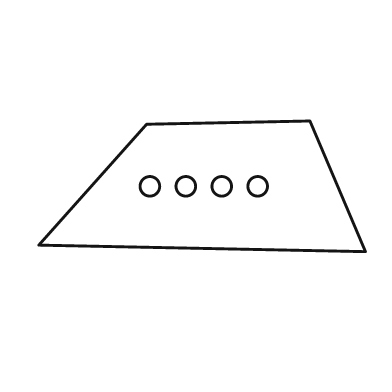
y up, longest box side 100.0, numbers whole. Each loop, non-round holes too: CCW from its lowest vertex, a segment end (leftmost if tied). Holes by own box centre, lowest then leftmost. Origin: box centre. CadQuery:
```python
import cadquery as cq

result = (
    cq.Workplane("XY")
    .moveTo(50.0, -20.0)
    .lineTo(33.0, 20.0)
    .lineTo(-17.0, 19.0)
    .lineTo(-50.0, -18.0)
    .close()
    .moveTo(-16.0, 0.0)
    .circle(3.0)
    .moveTo(-5.0, 0.0)
    .circle(3.0)
    .moveTo(6.0, 0.0)
    .circle(3.0)
    .moveTo(17.0, 0.0)
    .circle(3.0)
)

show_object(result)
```